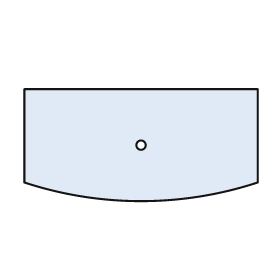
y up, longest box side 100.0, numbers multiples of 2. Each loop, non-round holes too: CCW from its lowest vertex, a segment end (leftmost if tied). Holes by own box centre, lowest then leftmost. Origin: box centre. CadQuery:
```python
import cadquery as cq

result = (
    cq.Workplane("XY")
    .moveTo(-50.0, -16.0)
    .threePointArc((0.0, -24.0), (50.0, -16.0))
    .lineTo(50.0, 24.0)
    .lineTo(-50.0, 24.0)
    .close()
    .moveTo(0.0, 0.0)
    .circle(2.0)
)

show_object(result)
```